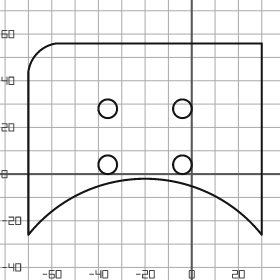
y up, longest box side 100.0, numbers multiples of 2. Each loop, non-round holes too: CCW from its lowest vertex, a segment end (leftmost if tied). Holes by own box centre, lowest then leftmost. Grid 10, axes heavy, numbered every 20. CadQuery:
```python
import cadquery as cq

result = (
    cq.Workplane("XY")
    .moveTo(-70.0, -26.0)
    .threePointArc((-20.0, -2.0), (30.0, -26.0))
    .lineTo(30.0, 56.0)
    .lineTo(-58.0, 56.0)
    .threePointArc((-66.0, 52.0), (-70.0, 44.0))
    .close()
    .moveTo(-36.0, 4.0)
    .circle(4.0)
    .moveTo(-4.0, 4.0)
    .circle(4.0)
    .moveTo(-36.0, 28.0)
    .circle(4.0)
    .moveTo(-4.0, 28.0)
    .circle(4.0)
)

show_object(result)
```